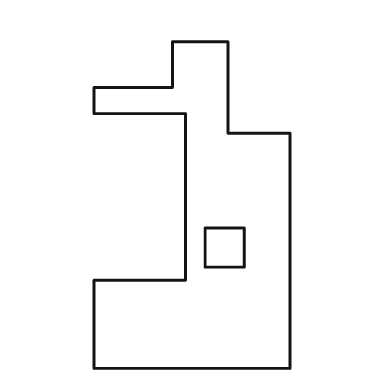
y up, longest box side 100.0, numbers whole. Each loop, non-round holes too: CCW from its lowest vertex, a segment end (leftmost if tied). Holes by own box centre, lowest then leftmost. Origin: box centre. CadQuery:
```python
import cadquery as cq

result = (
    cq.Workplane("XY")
    .moveTo(-30.0, -50.0)
    .lineTo(30.0, -50.0)
    .lineTo(30.0, 22.0)
    .lineTo(11.0, 22.0)
    .lineTo(11.0, 50.0)
    .lineTo(-6.0, 50.0)
    .lineTo(-6.0, 36.0)
    .lineTo(-30.0, 36.0)
    .lineTo(-30.0, 28.0)
    .lineTo(-2.0, 28.0)
    .lineTo(-2.0, -23.0)
    .lineTo(-30.0, -23.0)
    .close()
    .moveTo(4.0, -19.0)
    .lineTo(16.0, -19.0)
    .lineTo(16.0, -7.0)
    .lineTo(4.0, -7.0)
    .close()
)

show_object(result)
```